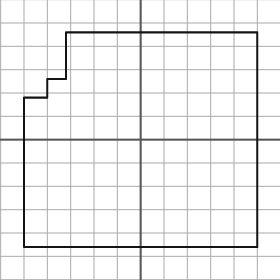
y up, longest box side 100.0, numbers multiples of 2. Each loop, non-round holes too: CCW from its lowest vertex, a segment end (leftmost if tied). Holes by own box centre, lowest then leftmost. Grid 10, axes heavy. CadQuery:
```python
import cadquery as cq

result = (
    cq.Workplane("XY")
    .moveTo(-50.0, -46.0)
    .lineTo(50.0, -46.0)
    .lineTo(50.0, 46.0)
    .lineTo(-32.0, 46.0)
    .lineTo(-32.0, 26.0)
    .lineTo(-40.0, 26.0)
    .lineTo(-40.0, 18.0)
    .lineTo(-50.0, 18.0)
    .close()
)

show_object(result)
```